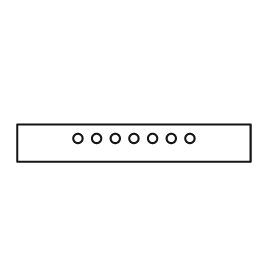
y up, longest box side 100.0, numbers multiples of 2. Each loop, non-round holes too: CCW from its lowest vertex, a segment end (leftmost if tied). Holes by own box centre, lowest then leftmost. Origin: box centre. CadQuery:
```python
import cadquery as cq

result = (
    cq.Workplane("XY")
    .moveTo(-50.0, -8.0)
    .lineTo(50.0, -8.0)
    .lineTo(50.0, 8.0)
    .lineTo(-50.0, 8.0)
    .close()
    .moveTo(-24.0, 2.0)
    .circle(2.0)
    .moveTo(-16.0, 2.0)
    .circle(2.0)
    .moveTo(-8.0, 2.0)
    .circle(2.0)
    .moveTo(0.0, 2.0)
    .circle(2.0)
    .moveTo(8.0, 2.0)
    .circle(2.0)
    .moveTo(16.0, 2.0)
    .circle(2.0)
    .moveTo(24.0, 2.0)
    .circle(2.0)
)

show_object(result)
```